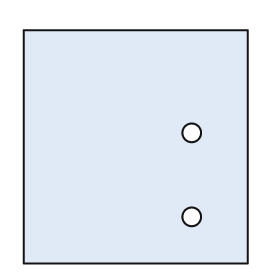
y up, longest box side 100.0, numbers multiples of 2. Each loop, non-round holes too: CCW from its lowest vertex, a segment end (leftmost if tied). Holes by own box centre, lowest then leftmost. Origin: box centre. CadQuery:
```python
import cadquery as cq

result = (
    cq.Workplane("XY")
    .moveTo(-48.0, -50.0)
    .lineTo(48.0, -50.0)
    .lineTo(48.0, 50.0)
    .lineTo(-48.0, 50.0)
    .close()
    .moveTo(24.0, -30.0)
    .circle(4.0)
    .moveTo(24.0, 6.0)
    .circle(4.0)
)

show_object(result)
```